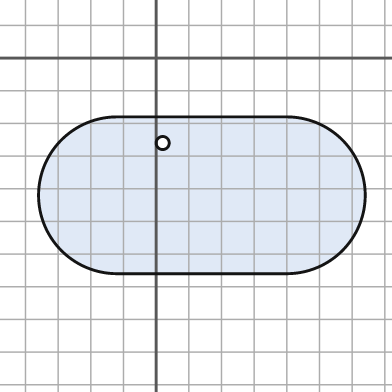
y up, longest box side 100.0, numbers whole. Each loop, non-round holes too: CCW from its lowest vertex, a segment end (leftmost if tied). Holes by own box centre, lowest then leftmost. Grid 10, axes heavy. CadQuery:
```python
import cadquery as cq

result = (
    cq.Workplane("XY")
    .moveTo(-12.0, -66.0)
    .lineTo(40.0, -66.0)
    .threePointArc((64.0, -42.0), (40.0, -18.0))
    .lineTo(-12.0, -18.0)
    .threePointArc((-36.0, -42.0), (-12.0, -66.0))
    .close()
    .moveTo(2.0, -26.0)
    .circle(2.0)
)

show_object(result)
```